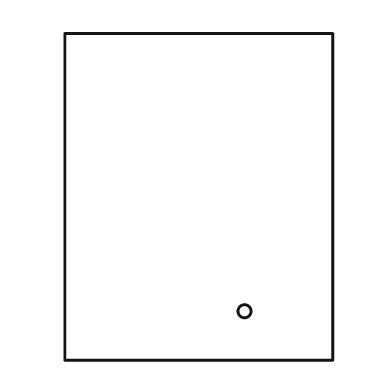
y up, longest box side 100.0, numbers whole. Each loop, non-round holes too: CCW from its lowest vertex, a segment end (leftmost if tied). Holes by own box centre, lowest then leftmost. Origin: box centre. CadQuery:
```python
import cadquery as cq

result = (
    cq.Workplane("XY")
    .moveTo(-41.0, -50.0)
    .lineTo(41.0, -50.0)
    .lineTo(41.0, 50.0)
    .lineTo(-41.0, 50.0)
    .close()
    .moveTo(14.0, -35.0)
    .circle(2.0)
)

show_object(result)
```